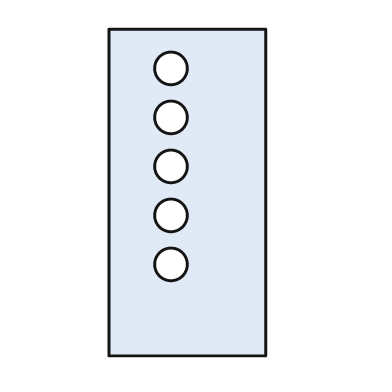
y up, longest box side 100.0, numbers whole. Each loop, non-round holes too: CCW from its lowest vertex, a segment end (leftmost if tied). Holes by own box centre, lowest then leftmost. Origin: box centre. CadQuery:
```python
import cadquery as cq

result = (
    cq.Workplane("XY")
    .moveTo(-24.0, -50.0)
    .lineTo(24.0, -50.0)
    .lineTo(24.0, 50.0)
    .lineTo(-24.0, 50.0)
    .close()
    .moveTo(-5.0, -22.0)
    .circle(5.0)
    .moveTo(-5.0, -7.0)
    .circle(5.0)
    .moveTo(-5.0, 8.0)
    .circle(5.0)
    .moveTo(-5.0, 23.0)
    .circle(5.0)
    .moveTo(-5.0, 38.0)
    .circle(5.0)
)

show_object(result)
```